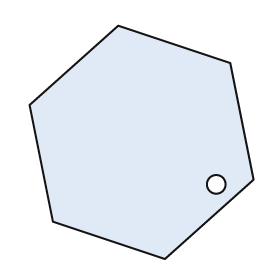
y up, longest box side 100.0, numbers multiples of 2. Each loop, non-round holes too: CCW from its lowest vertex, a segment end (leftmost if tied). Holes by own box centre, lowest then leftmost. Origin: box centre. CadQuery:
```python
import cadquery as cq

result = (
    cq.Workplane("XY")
    .moveTo(10.0, -50.0)
    .lineTo(48.0, -16.0)
    .lineTo(38.0, 34.0)
    .lineTo(-10.0, 50.0)
    .lineTo(-48.0, 16.0)
    .lineTo(-38.0, -34.0)
    .close()
    .moveTo(32.0, -18.0)
    .circle(4.0)
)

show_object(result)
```